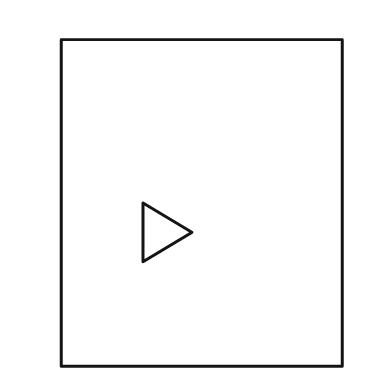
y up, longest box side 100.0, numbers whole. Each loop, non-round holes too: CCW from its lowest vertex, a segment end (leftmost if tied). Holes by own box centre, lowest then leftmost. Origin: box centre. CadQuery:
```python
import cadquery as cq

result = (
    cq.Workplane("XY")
    .moveTo(-43.0, -50.0)
    .lineTo(43.0, -50.0)
    .lineTo(43.0, 50.0)
    .lineTo(-43.0, 50.0)
    .close()
    .moveTo(-18.0, -18.0)
    .lineTo(-3.0, -9.0)
    .lineTo(-18.0, 0.0)
    .close()
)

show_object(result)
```